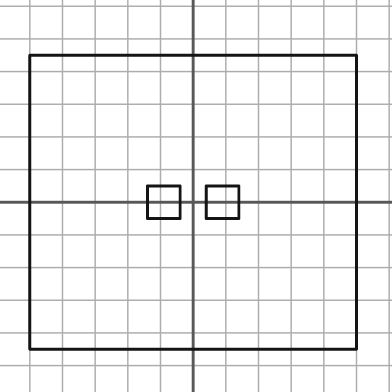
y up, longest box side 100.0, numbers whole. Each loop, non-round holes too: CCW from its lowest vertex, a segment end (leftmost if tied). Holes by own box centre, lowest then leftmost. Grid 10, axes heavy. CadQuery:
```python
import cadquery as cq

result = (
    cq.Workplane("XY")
    .moveTo(-50.0, -45.0)
    .lineTo(50.0, -45.0)
    .lineTo(50.0, 45.0)
    .lineTo(-50.0, 45.0)
    .close()
    .moveTo(-14.0, -5.0)
    .lineTo(-4.0, -5.0)
    .lineTo(-4.0, 5.0)
    .lineTo(-14.0, 5.0)
    .close()
    .moveTo(4.0, -5.0)
    .lineTo(14.0, -5.0)
    .lineTo(14.0, 5.0)
    .lineTo(4.0, 5.0)
    .close()
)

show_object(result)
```